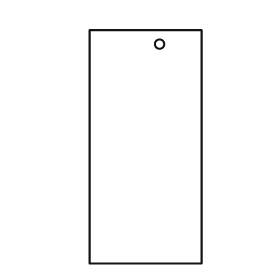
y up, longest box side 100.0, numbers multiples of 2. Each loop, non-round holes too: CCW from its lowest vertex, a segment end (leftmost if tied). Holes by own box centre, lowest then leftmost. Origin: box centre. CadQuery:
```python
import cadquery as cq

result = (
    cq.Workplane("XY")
    .moveTo(-24.0, -50.0)
    .lineTo(24.0, -50.0)
    .lineTo(24.0, 50.0)
    .lineTo(-24.0, 50.0)
    .close()
    .moveTo(6.0, 44.0)
    .circle(2.0)
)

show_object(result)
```